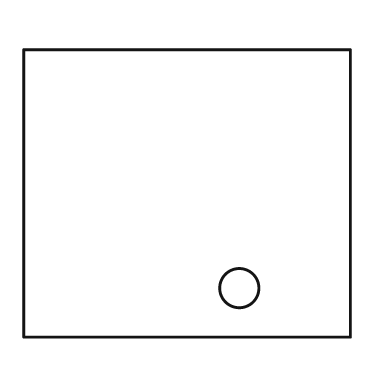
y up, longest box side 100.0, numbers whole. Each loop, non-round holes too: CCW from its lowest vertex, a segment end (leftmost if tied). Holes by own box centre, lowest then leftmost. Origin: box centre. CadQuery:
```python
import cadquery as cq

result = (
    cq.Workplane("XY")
    .moveTo(-50.0, -44.0)
    .lineTo(50.0, -44.0)
    .lineTo(50.0, 44.0)
    .lineTo(-50.0, 44.0)
    .close()
    .moveTo(16.0, -29.0)
    .circle(6.0)
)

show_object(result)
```